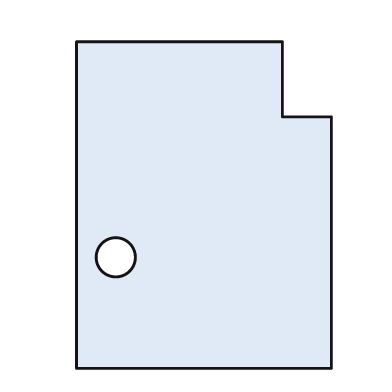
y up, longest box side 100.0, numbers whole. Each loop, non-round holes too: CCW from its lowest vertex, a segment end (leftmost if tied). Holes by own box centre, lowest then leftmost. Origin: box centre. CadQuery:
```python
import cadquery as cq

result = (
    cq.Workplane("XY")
    .moveTo(-39.0, -50.0)
    .lineTo(39.0, -50.0)
    .lineTo(39.0, 27.0)
    .lineTo(24.0, 27.0)
    .lineTo(24.0, 50.0)
    .lineTo(-39.0, 50.0)
    .close()
    .moveTo(-27.0, -16.0)
    .circle(6.0)
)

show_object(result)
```